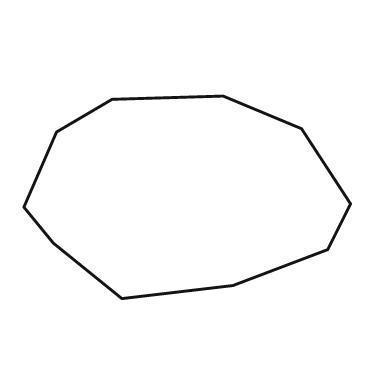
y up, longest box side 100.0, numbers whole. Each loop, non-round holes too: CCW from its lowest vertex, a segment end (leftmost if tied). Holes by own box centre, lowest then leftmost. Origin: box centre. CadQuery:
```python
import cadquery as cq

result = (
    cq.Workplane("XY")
    .moveTo(-20.0, -31.0)
    .lineTo(14.0, -27.0)
    .lineTo(43.0, -16.0)
    .lineTo(50.0, -2.0)
    .lineTo(35.0, 21.0)
    .lineTo(11.0, 31.0)
    .lineTo(-23.0, 30.0)
    .lineTo(-40.0, 20.0)
    .lineTo(-50.0, -3.0)
    .lineTo(-41.0, -14.0)
    .close()
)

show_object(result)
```